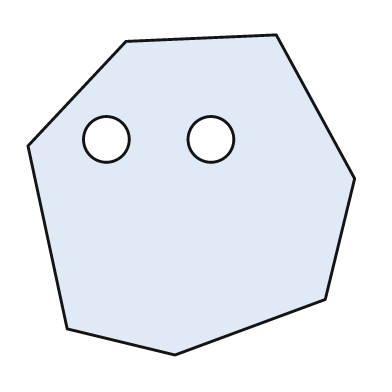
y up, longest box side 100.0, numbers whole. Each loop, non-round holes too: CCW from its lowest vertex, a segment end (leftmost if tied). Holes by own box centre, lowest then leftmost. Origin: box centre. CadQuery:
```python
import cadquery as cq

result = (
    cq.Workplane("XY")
    .moveTo(-5.0, -49.0)
    .lineTo(41.0, -32.0)
    .lineTo(50.0, 5.0)
    .lineTo(26.0, 49.0)
    .lineTo(-20.0, 47.0)
    .lineTo(-50.0, 15.0)
    .lineTo(-38.0, -41.0)
    .close()
    .moveTo(-26.0, 17.0)
    .circle(7.0)
    .moveTo(6.0, 17.0)
    .circle(7.0)
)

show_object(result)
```